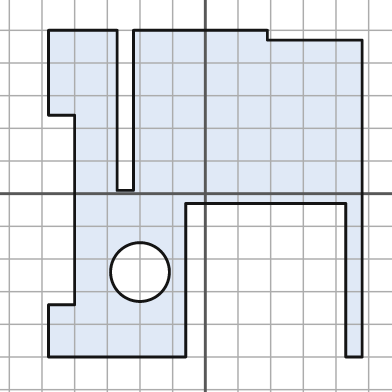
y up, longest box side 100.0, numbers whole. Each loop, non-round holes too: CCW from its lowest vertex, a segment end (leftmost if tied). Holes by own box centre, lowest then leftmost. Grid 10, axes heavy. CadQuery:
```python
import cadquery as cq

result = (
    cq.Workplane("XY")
    .moveTo(-48.0, -50.0)
    .lineTo(-6.0, -50.0)
    .lineTo(-6.0, -3.0)
    .lineTo(43.0, -3.0)
    .lineTo(43.0, -50.0)
    .lineTo(48.0, -50.0)
    .lineTo(48.0, 47.0)
    .lineTo(19.0, 47.0)
    .lineTo(19.0, 50.0)
    .lineTo(-22.0, 50.0)
    .lineTo(-22.0, 1.0)
    .lineTo(-27.0, 1.0)
    .lineTo(-27.0, 50.0)
    .lineTo(-48.0, 50.0)
    .lineTo(-48.0, 24.0)
    .lineTo(-40.0, 24.0)
    .lineTo(-40.0, -34.0)
    .lineTo(-48.0, -34.0)
    .close()
    .moveTo(-20.0, -24.0)
    .circle(9.0)
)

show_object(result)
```